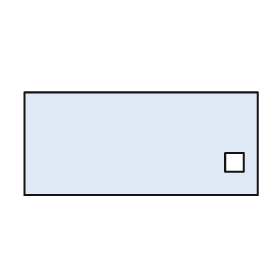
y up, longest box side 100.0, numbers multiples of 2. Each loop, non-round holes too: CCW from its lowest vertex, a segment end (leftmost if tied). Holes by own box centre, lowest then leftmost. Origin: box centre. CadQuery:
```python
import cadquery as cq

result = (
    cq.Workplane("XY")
    .moveTo(-50.0, -22.0)
    .lineTo(50.0, -22.0)
    .lineTo(50.0, 22.0)
    .lineTo(-50.0, 22.0)
    .close()
    .moveTo(36.0, -12.0)
    .lineTo(44.0, -12.0)
    .lineTo(44.0, -4.0)
    .lineTo(36.0, -4.0)
    .close()
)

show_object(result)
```